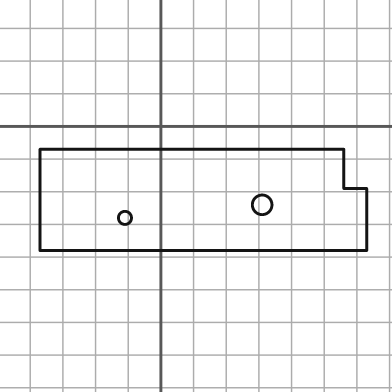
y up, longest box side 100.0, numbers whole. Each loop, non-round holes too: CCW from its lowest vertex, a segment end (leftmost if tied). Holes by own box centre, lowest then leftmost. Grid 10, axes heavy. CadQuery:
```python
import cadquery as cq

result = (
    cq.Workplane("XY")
    .moveTo(-37.0, -38.0)
    .lineTo(63.0, -38.0)
    .lineTo(63.0, -19.0)
    .lineTo(56.0, -19.0)
    .lineTo(56.0, -7.0)
    .lineTo(-37.0, -7.0)
    .close()
    .moveTo(-11.0, -28.0)
    .circle(2.0)
    .moveTo(31.0, -24.0)
    .circle(3.0)
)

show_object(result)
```